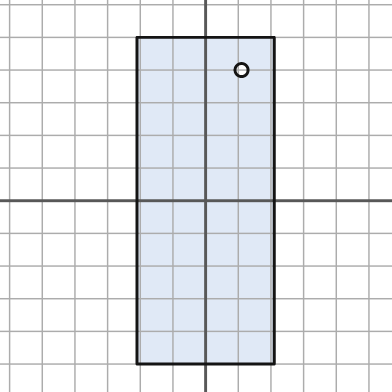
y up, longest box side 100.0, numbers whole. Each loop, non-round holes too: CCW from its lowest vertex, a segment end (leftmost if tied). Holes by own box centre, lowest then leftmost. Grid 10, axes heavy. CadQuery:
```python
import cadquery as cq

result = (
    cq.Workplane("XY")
    .moveTo(-21.0, -50.0)
    .lineTo(21.0, -50.0)
    .lineTo(21.0, 50.0)
    .lineTo(-21.0, 50.0)
    .close()
    .moveTo(11.0, 40.0)
    .circle(2.0)
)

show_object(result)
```